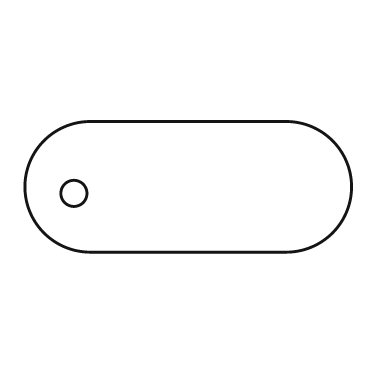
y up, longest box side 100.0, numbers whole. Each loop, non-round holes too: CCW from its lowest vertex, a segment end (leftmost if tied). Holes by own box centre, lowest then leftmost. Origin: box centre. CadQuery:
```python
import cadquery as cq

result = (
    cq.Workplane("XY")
    .moveTo(-30.0, -20.0)
    .lineTo(30.0, -20.0)
    .threePointArc((50.0, 0.0), (30.0, 20.0))
    .lineTo(-30.0, 20.0)
    .threePointArc((-50.0, 0.0), (-30.0, -20.0))
    .close()
    .moveTo(-35.0, -2.0)
    .circle(4.0)
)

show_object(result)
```